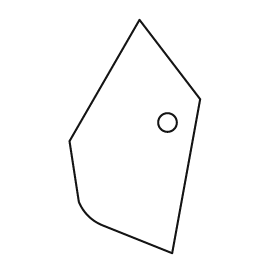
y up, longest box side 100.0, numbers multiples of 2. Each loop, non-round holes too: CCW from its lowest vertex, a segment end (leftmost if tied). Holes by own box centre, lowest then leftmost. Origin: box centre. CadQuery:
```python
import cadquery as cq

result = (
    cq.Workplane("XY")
    .moveTo(16.0, -50.0)
    .lineTo(28.0, 16.0)
    .lineTo(2.0, 50.0)
    .lineTo(-28.0, -2.0)
    .lineTo(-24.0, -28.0)
    .threePointArc((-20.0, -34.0), (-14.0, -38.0))
    .close()
    .moveTo(14.0, 6.0)
    .circle(4.0)
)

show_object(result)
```